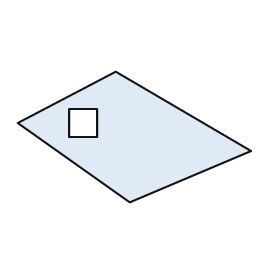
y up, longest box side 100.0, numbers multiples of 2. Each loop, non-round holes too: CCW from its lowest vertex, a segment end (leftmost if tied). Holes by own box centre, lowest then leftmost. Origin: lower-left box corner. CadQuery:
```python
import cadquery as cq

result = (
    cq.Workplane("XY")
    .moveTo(48.0, 0.0)
    .lineTo(100.0, 22.0)
    .lineTo(42.0, 56.0)
    .lineTo(0.0, 34.0)
    .close()
    .moveTo(22.0, 28.0)
    .lineTo(34.0, 28.0)
    .lineTo(34.0, 40.0)
    .lineTo(22.0, 40.0)
    .close()
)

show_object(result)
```